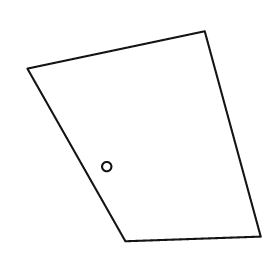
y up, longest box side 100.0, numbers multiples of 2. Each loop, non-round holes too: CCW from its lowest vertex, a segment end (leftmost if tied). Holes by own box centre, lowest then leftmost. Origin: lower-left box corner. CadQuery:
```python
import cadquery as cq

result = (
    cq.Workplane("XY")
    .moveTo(42.0, 0.0)
    .lineTo(100.0, 2.0)
    .lineTo(76.0, 90.0)
    .lineTo(0.0, 74.0)
    .close()
    .moveTo(34.0, 32.0)
    .circle(2.0)
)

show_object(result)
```